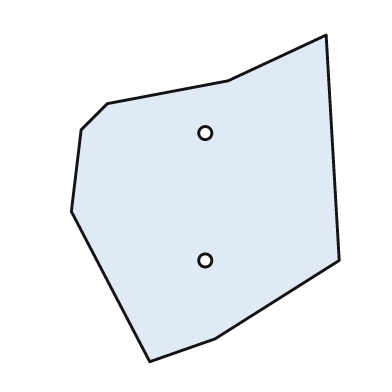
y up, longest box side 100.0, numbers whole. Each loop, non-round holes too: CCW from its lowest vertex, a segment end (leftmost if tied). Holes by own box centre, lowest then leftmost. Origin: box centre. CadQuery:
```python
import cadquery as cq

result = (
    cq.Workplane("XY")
    .moveTo(-17.0, -50.0)
    .lineTo(3.0, -43.0)
    .lineTo(41.0, -19.0)
    .lineTo(37.0, 50.0)
    .lineTo(7.0, 36.0)
    .lineTo(-30.0, 29.0)
    .lineTo(-38.0, 21.0)
    .lineTo(-41.0, -4.0)
    .close()
    .moveTo(0.0, -19.0)
    .circle(2.0)
    .moveTo(0.0, 20.0)
    .circle(2.0)
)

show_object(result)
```